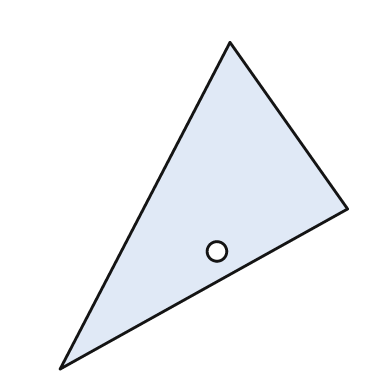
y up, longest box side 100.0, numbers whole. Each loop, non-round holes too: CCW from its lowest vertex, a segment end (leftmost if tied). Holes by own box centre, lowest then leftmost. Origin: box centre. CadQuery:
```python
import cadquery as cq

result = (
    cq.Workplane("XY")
    .moveTo(-44.0, -50.0)
    .lineTo(44.0, -1.0)
    .lineTo(8.0, 50.0)
    .close()
    .moveTo(4.0, -14.0)
    .circle(3.0)
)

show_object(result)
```